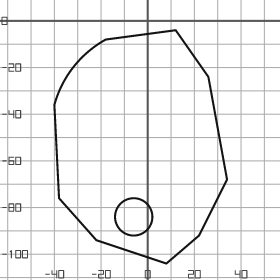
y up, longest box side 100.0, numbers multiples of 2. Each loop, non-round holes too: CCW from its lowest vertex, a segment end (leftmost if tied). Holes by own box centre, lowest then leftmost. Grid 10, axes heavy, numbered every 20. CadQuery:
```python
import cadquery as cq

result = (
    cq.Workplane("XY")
    .moveTo(8.0, -104.0)
    .lineTo(22.0, -92.0)
    .lineTo(34.0, -68.0)
    .lineTo(26.0, -24.0)
    .lineTo(12.0, -4.0)
    .lineTo(-18.0, -8.0)
    .threePointArc((-32.0, -20.0), (-40.0, -36.0))
    .lineTo(-38.0, -76.0)
    .lineTo(-22.0, -94.0)
    .close()
    .moveTo(-6.0, -84.0)
    .circle(8.0)
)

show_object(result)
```